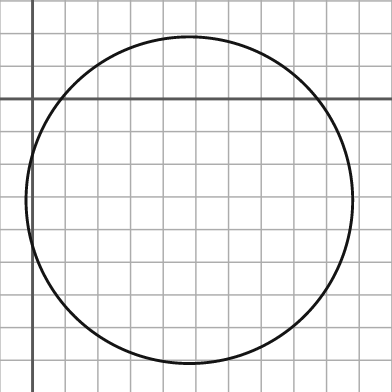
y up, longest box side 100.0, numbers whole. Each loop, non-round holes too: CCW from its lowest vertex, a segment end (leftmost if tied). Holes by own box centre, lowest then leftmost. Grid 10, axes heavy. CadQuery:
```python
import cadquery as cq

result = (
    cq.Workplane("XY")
    .moveTo(48.0, -31.0)
    .circle(50.0)
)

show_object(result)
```